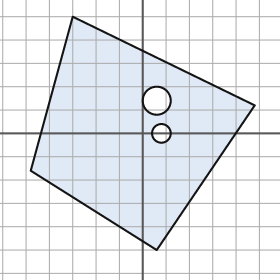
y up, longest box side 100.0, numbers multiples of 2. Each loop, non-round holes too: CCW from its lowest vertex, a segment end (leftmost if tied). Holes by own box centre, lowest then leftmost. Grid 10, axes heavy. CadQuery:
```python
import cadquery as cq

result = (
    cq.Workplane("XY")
    .moveTo(6.0, -50.0)
    .lineTo(48.0, 12.0)
    .lineTo(-30.0, 50.0)
    .lineTo(-48.0, -16.0)
    .close()
    .moveTo(8.0, 0.0)
    .circle(4.0)
    .moveTo(6.0, 14.0)
    .circle(6.0)
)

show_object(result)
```